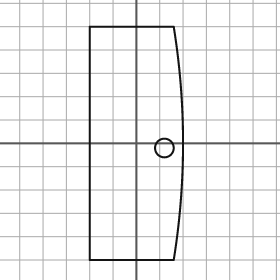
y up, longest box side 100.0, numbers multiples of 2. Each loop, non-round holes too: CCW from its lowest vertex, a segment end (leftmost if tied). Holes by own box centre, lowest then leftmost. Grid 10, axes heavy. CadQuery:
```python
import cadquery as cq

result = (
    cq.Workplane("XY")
    .moveTo(-20.0, -50.0)
    .lineTo(16.0, -50.0)
    .threePointArc((20.0, 0.0), (16.0, 50.0))
    .lineTo(-20.0, 50.0)
    .close()
    .moveTo(12.0, -2.0)
    .circle(4.0)
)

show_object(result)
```